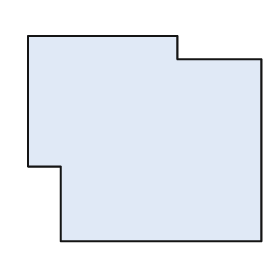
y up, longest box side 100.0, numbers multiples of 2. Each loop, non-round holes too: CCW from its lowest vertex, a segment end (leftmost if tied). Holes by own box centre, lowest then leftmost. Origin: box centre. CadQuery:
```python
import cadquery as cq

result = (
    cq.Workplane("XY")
    .moveTo(-36.0, -44.0)
    .lineTo(50.0, -44.0)
    .lineTo(50.0, 34.0)
    .lineTo(14.0, 34.0)
    .lineTo(14.0, 44.0)
    .lineTo(-50.0, 44.0)
    .lineTo(-50.0, -12.0)
    .lineTo(-36.0, -12.0)
    .close()
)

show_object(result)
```